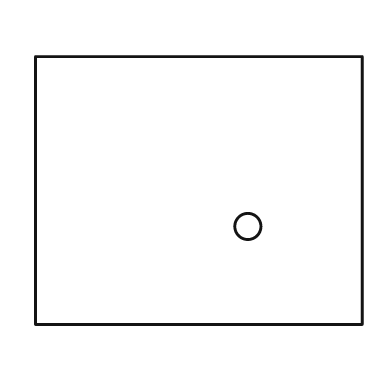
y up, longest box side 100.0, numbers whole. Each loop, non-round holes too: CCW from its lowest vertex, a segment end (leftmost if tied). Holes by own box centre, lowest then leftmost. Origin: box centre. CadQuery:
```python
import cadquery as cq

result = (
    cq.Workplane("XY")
    .moveTo(-50.0, -41.0)
    .lineTo(50.0, -41.0)
    .lineTo(50.0, 41.0)
    .lineTo(-50.0, 41.0)
    .close()
    .moveTo(15.0, -11.0)
    .circle(4.0)
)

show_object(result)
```